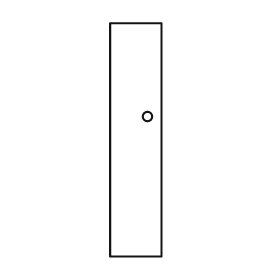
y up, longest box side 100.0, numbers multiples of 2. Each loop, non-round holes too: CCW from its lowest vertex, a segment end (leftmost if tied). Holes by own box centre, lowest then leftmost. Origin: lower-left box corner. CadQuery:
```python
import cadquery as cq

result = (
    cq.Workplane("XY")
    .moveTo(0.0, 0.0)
    .lineTo(22.0, 0.0)
    .lineTo(22.0, 100.0)
    .lineTo(0.0, 100.0)
    .close()
    .moveTo(16.0, 60.0)
    .circle(2.0)
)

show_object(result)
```